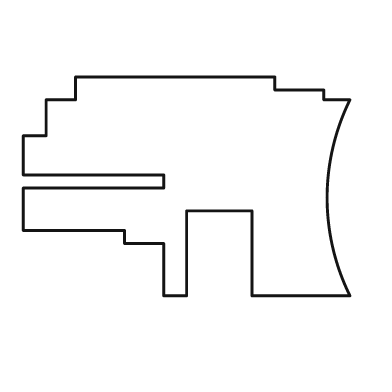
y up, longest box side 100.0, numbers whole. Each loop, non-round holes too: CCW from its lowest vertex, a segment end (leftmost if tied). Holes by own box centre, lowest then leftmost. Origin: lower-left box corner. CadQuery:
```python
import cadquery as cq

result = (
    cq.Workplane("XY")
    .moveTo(43.0, 0.0)
    .lineTo(50.0, 0.0)
    .lineTo(50.0, 26.0)
    .lineTo(70.0, 26.0)
    .lineTo(70.0, 0.0)
    .lineTo(100.0, 0.0)
    .threePointArc((93.0, 30.0), (100.0, 60.0))
    .lineTo(92.0, 60.0)
    .lineTo(92.0, 63.0)
    .lineTo(77.0, 63.0)
    .lineTo(77.0, 67.0)
    .lineTo(16.0, 67.0)
    .lineTo(16.0, 60.0)
    .lineTo(7.0, 60.0)
    .lineTo(7.0, 49.0)
    .lineTo(0.0, 49.0)
    .lineTo(0.0, 37.0)
    .lineTo(43.0, 37.0)
    .lineTo(43.0, 33.0)
    .lineTo(0.0, 33.0)
    .lineTo(0.0, 20.0)
    .lineTo(31.0, 20.0)
    .lineTo(31.0, 16.0)
    .lineTo(43.0, 16.0)
    .close()
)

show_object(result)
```